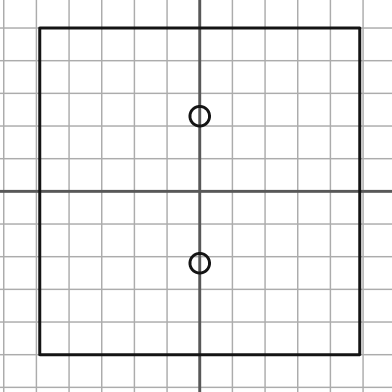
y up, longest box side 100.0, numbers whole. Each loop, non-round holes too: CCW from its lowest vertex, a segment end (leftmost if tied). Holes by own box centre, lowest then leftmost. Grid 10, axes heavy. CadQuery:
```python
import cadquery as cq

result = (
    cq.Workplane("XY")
    .moveTo(-49.0, -50.0)
    .lineTo(49.0, -50.0)
    .lineTo(49.0, 50.0)
    .lineTo(-49.0, 50.0)
    .close()
    .moveTo(0.0, -22.0)
    .circle(3.0)
    .moveTo(0.0, 23.0)
    .circle(3.0)
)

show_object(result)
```